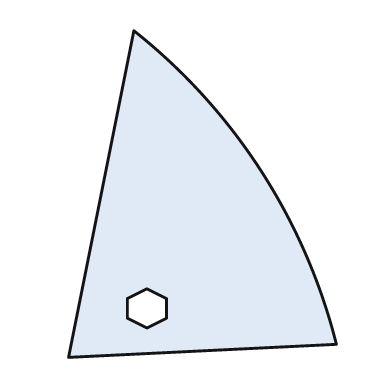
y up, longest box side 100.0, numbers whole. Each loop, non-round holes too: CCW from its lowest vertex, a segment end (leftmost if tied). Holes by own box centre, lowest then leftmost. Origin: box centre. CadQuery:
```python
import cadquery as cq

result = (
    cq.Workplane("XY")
    .moveTo(-41.0, -50.0)
    .lineTo(41.0, -46.0)
    .threePointArc((18.0, 7.0), (-21.0, 50.0))
    .close()
    .moveTo(-17.0, -41.0)
    .lineTo(-11.0, -38.0)
    .lineTo(-11.0, -32.0)
    .lineTo(-17.0, -29.0)
    .lineTo(-23.0, -32.0)
    .lineTo(-23.0, -38.0)
    .close()
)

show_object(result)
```